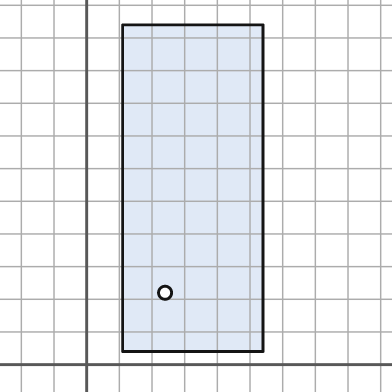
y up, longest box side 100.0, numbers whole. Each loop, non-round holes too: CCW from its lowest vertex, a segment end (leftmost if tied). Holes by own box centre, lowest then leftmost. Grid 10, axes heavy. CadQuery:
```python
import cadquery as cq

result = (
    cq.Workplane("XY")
    .moveTo(11.0, 4.0)
    .lineTo(54.0, 4.0)
    .lineTo(54.0, 104.0)
    .lineTo(11.0, 104.0)
    .close()
    .moveTo(24.0, 22.0)
    .circle(2.0)
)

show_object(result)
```